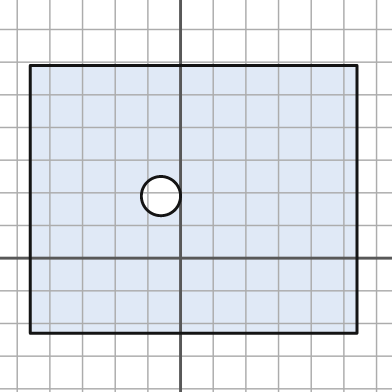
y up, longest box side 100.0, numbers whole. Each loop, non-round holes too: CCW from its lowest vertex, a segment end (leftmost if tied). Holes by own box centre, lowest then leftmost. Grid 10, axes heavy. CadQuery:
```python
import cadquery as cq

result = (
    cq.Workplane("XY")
    .moveTo(-46.0, -23.0)
    .lineTo(54.0, -23.0)
    .lineTo(54.0, 59.0)
    .lineTo(-46.0, 59.0)
    .close()
    .moveTo(-6.0, 19.0)
    .circle(6.0)
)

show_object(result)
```